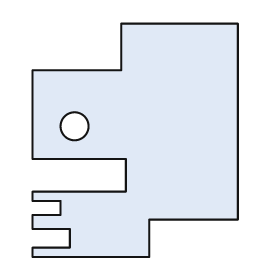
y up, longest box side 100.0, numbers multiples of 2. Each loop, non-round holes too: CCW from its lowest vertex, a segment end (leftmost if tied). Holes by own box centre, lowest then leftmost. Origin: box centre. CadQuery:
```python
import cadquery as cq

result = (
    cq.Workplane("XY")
    .moveTo(-44.0, -50.0)
    .lineTo(6.0, -50.0)
    .lineTo(6.0, -34.0)
    .lineTo(44.0, -34.0)
    .lineTo(44.0, 50.0)
    .lineTo(-6.0, 50.0)
    .lineTo(-6.0, 30.0)
    .lineTo(-44.0, 30.0)
    .lineTo(-44.0, -8.0)
    .lineTo(-4.0, -8.0)
    .lineTo(-4.0, -22.0)
    .lineTo(-44.0, -22.0)
    .lineTo(-44.0, -26.0)
    .lineTo(-32.0, -26.0)
    .lineTo(-32.0, -32.0)
    .lineTo(-44.0, -32.0)
    .lineTo(-44.0, -38.0)
    .lineTo(-28.0, -38.0)
    .lineTo(-28.0, -46.0)
    .lineTo(-44.0, -46.0)
    .close()
    .moveTo(-26.0, 6.0)
    .circle(6.0)
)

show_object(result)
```